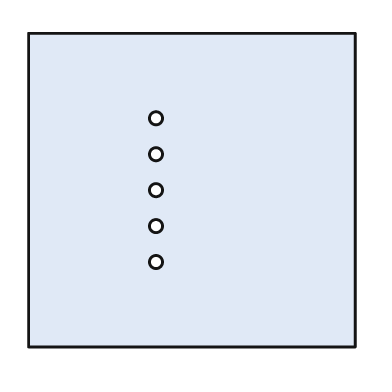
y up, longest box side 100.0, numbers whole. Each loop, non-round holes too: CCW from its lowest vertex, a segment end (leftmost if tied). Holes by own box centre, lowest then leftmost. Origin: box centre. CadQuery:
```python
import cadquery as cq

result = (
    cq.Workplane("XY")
    .moveTo(-50.0, -48.0)
    .lineTo(50.0, -48.0)
    .lineTo(50.0, 48.0)
    .lineTo(-50.0, 48.0)
    .close()
    .moveTo(-11.0, -22.0)
    .circle(2.0)
    .moveTo(-11.0, -11.0)
    .circle(2.0)
    .moveTo(-11.0, 0.0)
    .circle(2.0)
    .moveTo(-11.0, 11.0)
    .circle(2.0)
    .moveTo(-11.0, 22.0)
    .circle(2.0)
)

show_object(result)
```